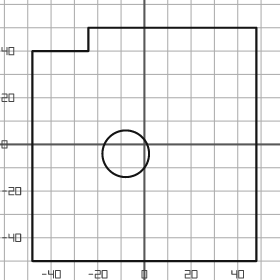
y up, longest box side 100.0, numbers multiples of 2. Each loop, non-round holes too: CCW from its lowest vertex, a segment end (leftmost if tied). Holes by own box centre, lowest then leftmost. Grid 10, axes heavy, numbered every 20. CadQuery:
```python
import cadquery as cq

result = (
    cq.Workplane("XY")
    .moveTo(-48.0, -50.0)
    .lineTo(48.0, -50.0)
    .lineTo(48.0, 50.0)
    .lineTo(-24.0, 50.0)
    .lineTo(-24.0, 40.0)
    .lineTo(-48.0, 40.0)
    .close()
    .moveTo(-8.0, -4.0)
    .circle(10.0)
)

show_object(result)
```